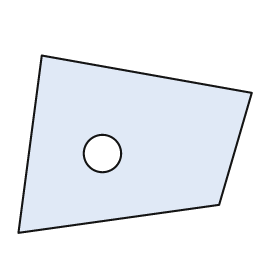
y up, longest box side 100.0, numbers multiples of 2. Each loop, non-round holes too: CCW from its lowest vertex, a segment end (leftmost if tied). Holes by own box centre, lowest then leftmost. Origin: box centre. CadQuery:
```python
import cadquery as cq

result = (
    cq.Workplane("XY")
    .moveTo(-50.0, -38.0)
    .lineTo(36.0, -26.0)
    .lineTo(50.0, 22.0)
    .lineTo(-40.0, 38.0)
    .close()
    .moveTo(-14.0, -4.0)
    .circle(8.0)
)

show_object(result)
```